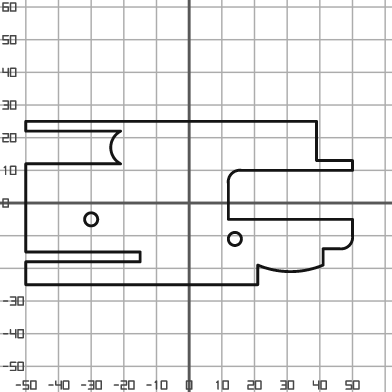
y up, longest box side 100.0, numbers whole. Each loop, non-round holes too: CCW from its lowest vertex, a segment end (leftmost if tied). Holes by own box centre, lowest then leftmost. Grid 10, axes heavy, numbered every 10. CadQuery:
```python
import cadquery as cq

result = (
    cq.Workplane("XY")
    .moveTo(-50.0, -25.0)
    .lineTo(21.0, -25.0)
    .lineTo(21.0, -19.0)
    .threePointArc((31.0, -21.0), (41.0, -19.0))
    .lineTo(41.0, -14.0)
    .lineTo(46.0, -14.0)
    .threePointArc((49.0, -13.0), (50.0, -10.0))
    .lineTo(50.0, -5.0)
    .lineTo(12.0, -5.0)
    .lineTo(12.0, 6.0)
    .threePointArc((13.0, 9.0), (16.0, 10.0))
    .lineTo(50.0, 10.0)
    .lineTo(50.0, 13.0)
    .lineTo(39.0, 13.0)
    .lineTo(39.0, 25.0)
    .lineTo(-50.0, 25.0)
    .lineTo(-50.0, 22.0)
    .lineTo(-21.0, 22.0)
    .threePointArc((-24.0, 17.0), (-21.0, 12.0))
    .lineTo(-50.0, 12.0)
    .lineTo(-50.0, -15.0)
    .lineTo(-15.0, -15.0)
    .lineTo(-15.0, -18.0)
    .lineTo(-50.0, -18.0)
    .close()
    .moveTo(14.0, -11.0)
    .circle(2.0)
    .moveTo(-30.0, -5.0)
    .circle(2.0)
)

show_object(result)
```